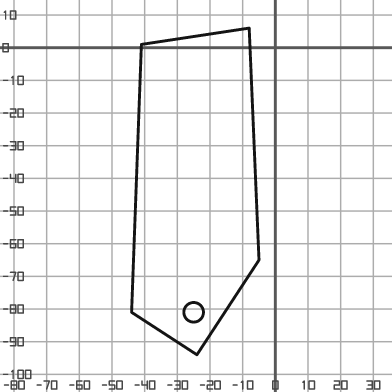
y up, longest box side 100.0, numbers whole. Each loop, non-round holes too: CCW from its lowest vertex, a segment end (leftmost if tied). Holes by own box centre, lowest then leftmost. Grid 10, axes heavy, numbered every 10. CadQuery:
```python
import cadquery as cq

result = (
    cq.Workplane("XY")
    .moveTo(-24.0, -94.0)
    .lineTo(-5.0, -65.0)
    .lineTo(-8.0, 6.0)
    .lineTo(-41.0, 1.0)
    .lineTo(-44.0, -81.0)
    .close()
    .moveTo(-25.0, -81.0)
    .circle(3.0)
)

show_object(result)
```